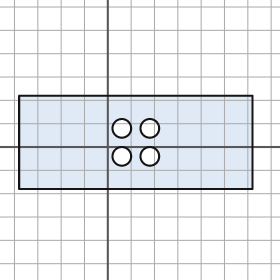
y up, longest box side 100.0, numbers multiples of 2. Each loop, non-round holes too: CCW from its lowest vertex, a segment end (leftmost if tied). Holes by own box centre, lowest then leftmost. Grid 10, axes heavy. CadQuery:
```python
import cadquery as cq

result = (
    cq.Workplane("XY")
    .moveTo(-38.0, -18.0)
    .lineTo(62.0, -18.0)
    .lineTo(62.0, 22.0)
    .lineTo(-38.0, 22.0)
    .close()
    .moveTo(6.0, -4.0)
    .circle(4.0)
    .moveTo(18.0, -4.0)
    .circle(4.0)
    .moveTo(6.0, 8.0)
    .circle(4.0)
    .moveTo(18.0, 8.0)
    .circle(4.0)
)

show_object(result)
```